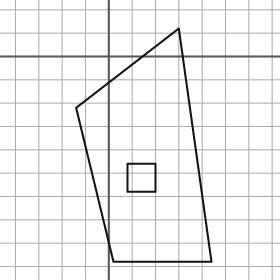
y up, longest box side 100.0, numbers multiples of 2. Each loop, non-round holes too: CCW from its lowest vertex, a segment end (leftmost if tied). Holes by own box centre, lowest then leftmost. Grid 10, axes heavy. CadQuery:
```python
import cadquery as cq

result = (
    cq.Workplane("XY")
    .moveTo(2.0, -88.0)
    .lineTo(44.0, -88.0)
    .lineTo(30.0, 12.0)
    .lineTo(-14.0, -22.0)
    .close()
    .moveTo(8.0, -58.0)
    .lineTo(20.0, -58.0)
    .lineTo(20.0, -46.0)
    .lineTo(8.0, -46.0)
    .close()
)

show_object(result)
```